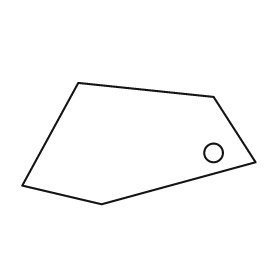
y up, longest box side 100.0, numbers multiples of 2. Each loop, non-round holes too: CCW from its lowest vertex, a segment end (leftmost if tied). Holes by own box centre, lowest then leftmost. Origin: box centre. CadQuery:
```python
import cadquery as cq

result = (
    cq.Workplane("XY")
    .moveTo(-16.0, -26.0)
    .lineTo(50.0, -8.0)
    .lineTo(32.0, 20.0)
    .lineTo(-26.0, 26.0)
    .lineTo(-50.0, -18.0)
    .close()
    .moveTo(32.0, -4.0)
    .circle(4.0)
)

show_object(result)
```